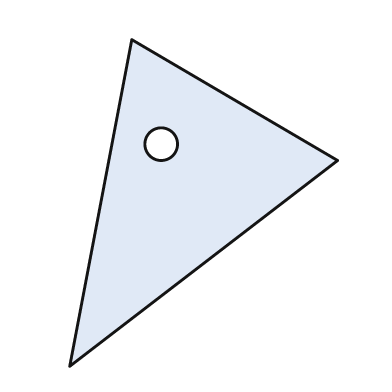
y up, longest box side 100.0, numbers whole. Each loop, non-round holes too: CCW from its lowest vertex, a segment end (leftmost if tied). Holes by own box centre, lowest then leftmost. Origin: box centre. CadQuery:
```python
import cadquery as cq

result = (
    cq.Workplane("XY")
    .moveTo(-41.0, -50.0)
    .lineTo(41.0, 13.0)
    .lineTo(-22.0, 50.0)
    .close()
    .moveTo(-13.0, 18.0)
    .circle(5.0)
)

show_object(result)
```